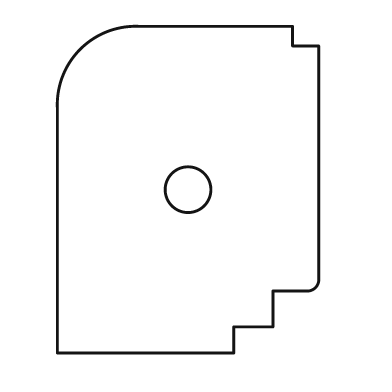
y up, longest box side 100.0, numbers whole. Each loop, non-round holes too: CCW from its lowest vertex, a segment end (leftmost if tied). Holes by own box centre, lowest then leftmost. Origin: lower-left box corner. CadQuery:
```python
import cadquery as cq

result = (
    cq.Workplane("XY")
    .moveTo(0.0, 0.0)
    .lineTo(54.0, 0.0)
    .lineTo(54.0, 8.0)
    .lineTo(66.0, 8.0)
    .lineTo(66.0, 19.0)
    .lineTo(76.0, 19.0)
    .threePointArc((79.0, 20.0), (80.0, 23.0))
    .lineTo(80.0, 94.0)
    .lineTo(72.0, 94.0)
    .lineTo(72.0, 100.0)
    .lineTo(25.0, 100.0)
    .threePointArc((7.0, 93.0), (0.0, 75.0))
    .close()
    .moveTo(40.0, 50.0)
    .circle(7.0)
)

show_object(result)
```